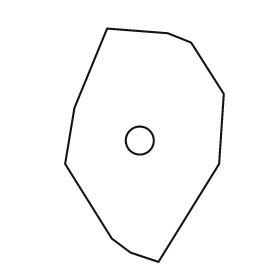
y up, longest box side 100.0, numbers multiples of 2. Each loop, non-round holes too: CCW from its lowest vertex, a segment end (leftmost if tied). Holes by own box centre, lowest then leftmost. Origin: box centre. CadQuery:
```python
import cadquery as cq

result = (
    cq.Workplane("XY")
    .moveTo(6.0, -50.0)
    .lineTo(32.0, -8.0)
    .lineTo(34.0, 22.0)
    .lineTo(20.0, 44.0)
    .lineTo(10.0, 48.0)
    .lineTo(-16.0, 50.0)
    .lineTo(-30.0, 16.0)
    .lineTo(-34.0, -8.0)
    .lineTo(-14.0, -40.0)
    .lineTo(-6.0, -46.0)
    .close()
    .moveTo(-2.0, 2.0)
    .circle(6.0)
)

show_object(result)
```